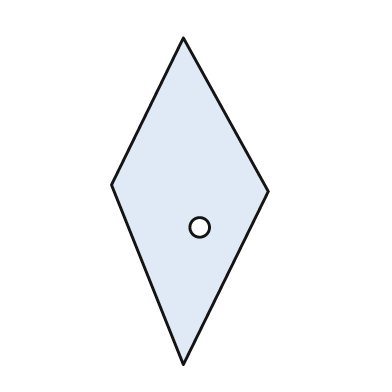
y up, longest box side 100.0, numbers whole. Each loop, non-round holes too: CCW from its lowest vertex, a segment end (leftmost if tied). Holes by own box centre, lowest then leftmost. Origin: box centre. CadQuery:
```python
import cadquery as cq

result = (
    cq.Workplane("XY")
    .moveTo(-2.0, -50.0)
    .lineTo(24.0, 3.0)
    .lineTo(-2.0, 50.0)
    .lineTo(-24.0, 5.0)
    .close()
    .moveTo(3.0, -8.0)
    .circle(3.0)
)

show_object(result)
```